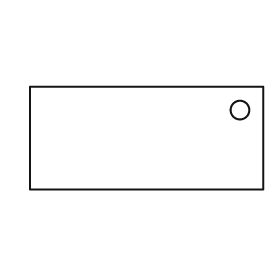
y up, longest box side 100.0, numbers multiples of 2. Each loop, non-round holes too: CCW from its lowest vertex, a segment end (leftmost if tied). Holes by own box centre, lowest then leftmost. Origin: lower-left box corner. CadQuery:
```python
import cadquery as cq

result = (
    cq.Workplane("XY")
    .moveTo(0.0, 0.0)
    .lineTo(100.0, 0.0)
    .lineTo(100.0, 44.0)
    .lineTo(0.0, 44.0)
    .close()
    .moveTo(90.0, 34.0)
    .circle(4.0)
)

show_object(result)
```